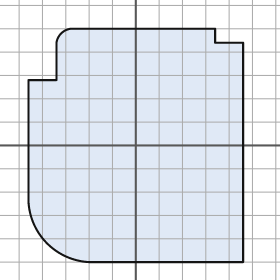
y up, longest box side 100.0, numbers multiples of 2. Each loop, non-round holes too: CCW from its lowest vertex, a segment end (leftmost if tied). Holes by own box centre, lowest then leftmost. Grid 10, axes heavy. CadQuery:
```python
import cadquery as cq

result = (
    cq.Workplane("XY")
    .moveTo(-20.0, -50.0)
    .lineTo(46.0, -50.0)
    .lineTo(46.0, 44.0)
    .lineTo(34.0, 44.0)
    .lineTo(34.0, 50.0)
    .lineTo(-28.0, 50.0)
    .threePointArc((-32.0, 48.0), (-34.0, 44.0))
    .lineTo(-34.0, 28.0)
    .lineTo(-46.0, 28.0)
    .lineTo(-46.0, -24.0)
    .threePointArc((-38.0, -42.0), (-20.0, -50.0))
    .close()
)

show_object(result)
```